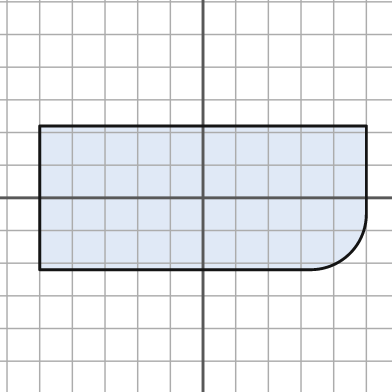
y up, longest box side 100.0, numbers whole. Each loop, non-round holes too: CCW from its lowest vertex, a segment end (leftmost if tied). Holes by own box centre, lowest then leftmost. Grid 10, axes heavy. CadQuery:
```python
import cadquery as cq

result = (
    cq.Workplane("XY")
    .moveTo(-50.0, -22.0)
    .lineTo(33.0, -22.0)
    .threePointArc((45.0, -17.0), (50.0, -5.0))
    .lineTo(50.0, 22.0)
    .lineTo(-50.0, 22.0)
    .close()
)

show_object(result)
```